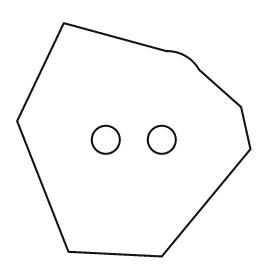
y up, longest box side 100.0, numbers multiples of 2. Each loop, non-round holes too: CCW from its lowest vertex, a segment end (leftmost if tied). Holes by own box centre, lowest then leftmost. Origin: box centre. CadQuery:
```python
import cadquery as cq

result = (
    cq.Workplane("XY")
    .moveTo(12.0, -50.0)
    .lineTo(50.0, -4.0)
    .lineTo(46.0, 14.0)
    .lineTo(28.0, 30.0)
    .threePointArc((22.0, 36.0), (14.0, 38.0))
    .lineTo(-30.0, 50.0)
    .lineTo(-50.0, 8.0)
    .lineTo(-28.0, -48.0)
    .close()
    .moveTo(-12.0, 0.0)
    .circle(6.0)
    .moveTo(12.0, 0.0)
    .circle(6.0)
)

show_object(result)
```